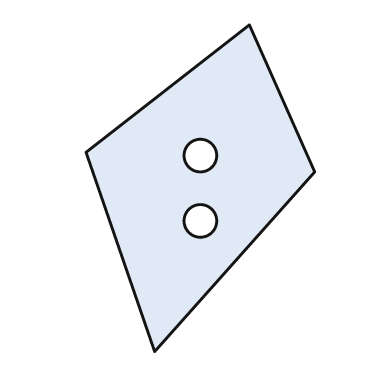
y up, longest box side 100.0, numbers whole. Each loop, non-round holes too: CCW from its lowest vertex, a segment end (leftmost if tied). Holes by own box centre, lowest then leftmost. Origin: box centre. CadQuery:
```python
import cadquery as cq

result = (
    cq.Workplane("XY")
    .moveTo(-14.0, -50.0)
    .lineTo(35.0, 5.0)
    .lineTo(15.0, 50.0)
    .lineTo(-35.0, 11.0)
    .close()
    .moveTo(0.0, -10.0)
    .circle(5.0)
    .moveTo(0.0, 10.0)
    .circle(5.0)
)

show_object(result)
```